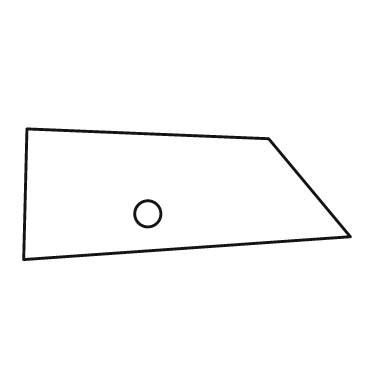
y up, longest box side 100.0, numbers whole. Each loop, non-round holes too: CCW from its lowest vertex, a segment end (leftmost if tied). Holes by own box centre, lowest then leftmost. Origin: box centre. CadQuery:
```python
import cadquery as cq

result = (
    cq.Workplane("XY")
    .moveTo(-50.0, -20.0)
    .lineTo(50.0, -13.0)
    .lineTo(25.0, 17.0)
    .lineTo(-49.0, 20.0)
    .close()
    .moveTo(-12.0, -6.0)
    .circle(4.0)
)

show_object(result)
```